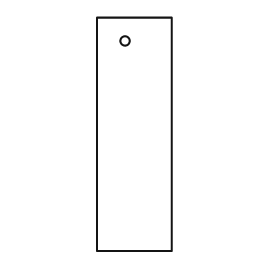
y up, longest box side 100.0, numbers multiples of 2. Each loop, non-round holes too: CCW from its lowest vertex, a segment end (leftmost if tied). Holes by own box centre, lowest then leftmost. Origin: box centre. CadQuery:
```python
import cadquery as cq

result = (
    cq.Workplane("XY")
    .moveTo(-16.0, -50.0)
    .lineTo(16.0, -50.0)
    .lineTo(16.0, 50.0)
    .lineTo(-16.0, 50.0)
    .close()
    .moveTo(-4.0, 40.0)
    .circle(2.0)
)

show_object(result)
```